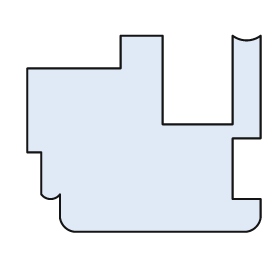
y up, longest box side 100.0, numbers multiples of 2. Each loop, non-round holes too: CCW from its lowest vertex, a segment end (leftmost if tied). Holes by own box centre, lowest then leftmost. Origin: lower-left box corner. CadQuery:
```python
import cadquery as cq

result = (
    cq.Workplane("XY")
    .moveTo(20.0, 0.0)
    .lineTo(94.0, 0.0)
    .threePointArc((98.0, 2.0), (100.0, 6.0))
    .lineTo(100.0, 14.0)
    .lineTo(88.0, 14.0)
    .lineTo(88.0, 40.0)
    .lineTo(100.0, 40.0)
    .lineTo(100.0, 84.0)
    .threePointArc((94.0, 82.0), (88.0, 84.0))
    .lineTo(88.0, 46.0)
    .lineTo(58.0, 46.0)
    .lineTo(58.0, 84.0)
    .lineTo(40.0, 84.0)
    .lineTo(40.0, 70.0)
    .lineTo(0.0, 70.0)
    .lineTo(0.0, 34.0)
    .lineTo(6.0, 34.0)
    .lineTo(6.0, 16.0)
    .threePointArc((10.0, 14.0), (14.0, 16.0))
    .lineTo(14.0, 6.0)
    .threePointArc((16.0, 2.0), (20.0, 0.0))
    .close()
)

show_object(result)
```